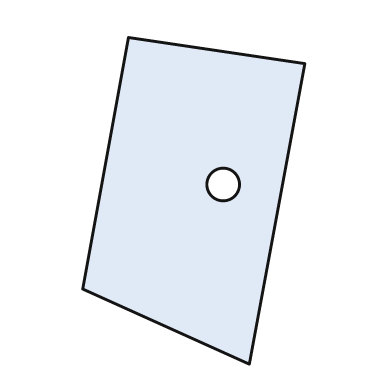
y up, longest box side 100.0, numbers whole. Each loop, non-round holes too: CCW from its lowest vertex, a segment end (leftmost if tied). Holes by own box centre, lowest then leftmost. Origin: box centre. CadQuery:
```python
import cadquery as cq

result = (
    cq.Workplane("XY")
    .moveTo(17.0, -50.0)
    .lineTo(34.0, 42.0)
    .lineTo(-20.0, 50.0)
    .lineTo(-34.0, -27.0)
    .close()
    .moveTo(9.0, 5.0)
    .circle(5.0)
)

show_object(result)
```